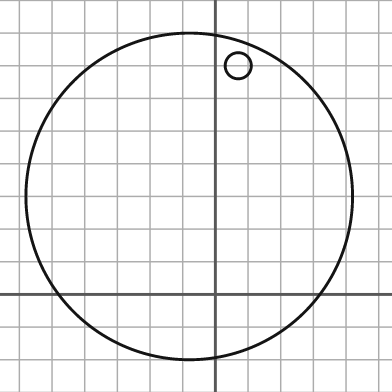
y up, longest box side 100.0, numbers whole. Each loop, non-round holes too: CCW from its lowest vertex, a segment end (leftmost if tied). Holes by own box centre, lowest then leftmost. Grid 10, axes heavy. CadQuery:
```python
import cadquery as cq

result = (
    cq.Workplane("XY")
    .moveTo(-8.0, 30.0)
    .circle(50.0)
    .moveTo(7.0, 70.0)
    .circle(4.0)
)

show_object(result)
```